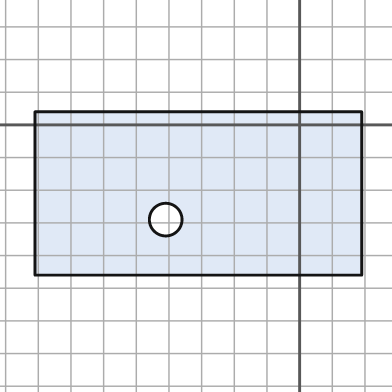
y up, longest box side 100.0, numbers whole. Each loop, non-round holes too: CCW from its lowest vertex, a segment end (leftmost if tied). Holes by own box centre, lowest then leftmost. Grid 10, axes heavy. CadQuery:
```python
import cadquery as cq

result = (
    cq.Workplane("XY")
    .moveTo(-81.0, -46.0)
    .lineTo(19.0, -46.0)
    .lineTo(19.0, 4.0)
    .lineTo(-81.0, 4.0)
    .close()
    .moveTo(-41.0, -29.0)
    .circle(5.0)
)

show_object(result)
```